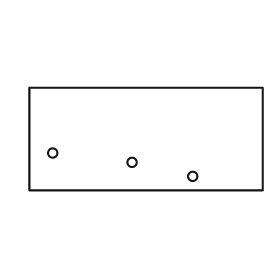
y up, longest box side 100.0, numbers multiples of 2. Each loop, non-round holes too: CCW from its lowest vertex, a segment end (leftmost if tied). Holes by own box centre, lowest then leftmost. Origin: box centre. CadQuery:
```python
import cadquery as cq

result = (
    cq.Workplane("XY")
    .moveTo(-50.0, -22.0)
    .lineTo(50.0, -22.0)
    .lineTo(50.0, 22.0)
    .lineTo(-50.0, 22.0)
    .close()
    .moveTo(20.0, -16.0)
    .circle(2.0)
    .moveTo(-6.0, -10.0)
    .circle(2.0)
    .moveTo(-40.0, -6.0)
    .circle(2.0)
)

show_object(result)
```